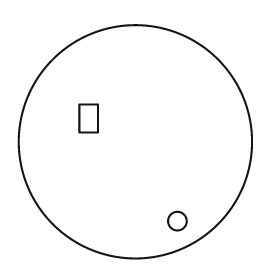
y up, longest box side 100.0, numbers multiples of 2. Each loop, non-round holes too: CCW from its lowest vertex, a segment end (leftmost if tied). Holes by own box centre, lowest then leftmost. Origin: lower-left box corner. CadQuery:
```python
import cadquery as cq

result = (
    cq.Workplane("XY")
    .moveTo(50.0, 50.0)
    .circle(50.0)
    .moveTo(68.0, 16.0)
    .circle(4.0)
    .moveTo(26.0, 54.0)
    .lineTo(34.0, 54.0)
    .lineTo(34.0, 66.0)
    .lineTo(26.0, 66.0)
    .close()
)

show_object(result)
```